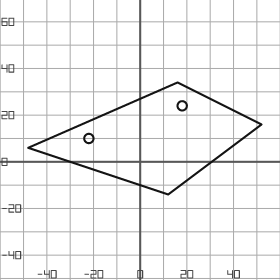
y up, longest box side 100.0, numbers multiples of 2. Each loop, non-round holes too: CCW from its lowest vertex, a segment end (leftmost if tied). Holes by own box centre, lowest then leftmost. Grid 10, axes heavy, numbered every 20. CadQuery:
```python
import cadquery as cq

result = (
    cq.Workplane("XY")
    .moveTo(12.0, -14.0)
    .lineTo(52.0, 16.0)
    .lineTo(16.0, 34.0)
    .lineTo(-48.0, 6.0)
    .close()
    .moveTo(-22.0, 10.0)
    .circle(2.0)
    .moveTo(18.0, 24.0)
    .circle(2.0)
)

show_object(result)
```